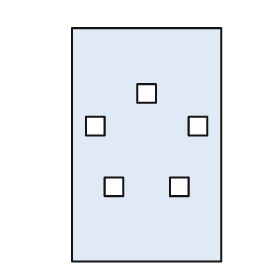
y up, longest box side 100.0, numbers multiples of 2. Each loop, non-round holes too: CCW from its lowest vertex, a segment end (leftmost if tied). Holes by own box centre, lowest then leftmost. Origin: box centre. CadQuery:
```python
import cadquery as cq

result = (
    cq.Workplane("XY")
    .moveTo(-32.0, -50.0)
    .lineTo(32.0, -50.0)
    .lineTo(32.0, 50.0)
    .lineTo(-32.0, 50.0)
    .close()
    .moveTo(-18.0, -22.0)
    .lineTo(-10.0, -22.0)
    .lineTo(-10.0, -14.0)
    .lineTo(-18.0, -14.0)
    .close()
    .moveTo(10.0, -22.0)
    .lineTo(18.0, -22.0)
    .lineTo(18.0, -14.0)
    .lineTo(10.0, -14.0)
    .close()
    .moveTo(-26.0, 4.0)
    .lineTo(-18.0, 4.0)
    .lineTo(-18.0, 12.0)
    .lineTo(-26.0, 12.0)
    .close()
    .moveTo(18.0, 4.0)
    .lineTo(26.0, 4.0)
    .lineTo(26.0, 12.0)
    .lineTo(18.0, 12.0)
    .close()
    .moveTo(-4.0, 18.0)
    .lineTo(4.0, 18.0)
    .lineTo(4.0, 26.0)
    .lineTo(-4.0, 26.0)
    .close()
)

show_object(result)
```